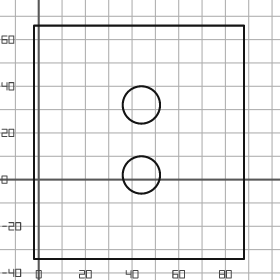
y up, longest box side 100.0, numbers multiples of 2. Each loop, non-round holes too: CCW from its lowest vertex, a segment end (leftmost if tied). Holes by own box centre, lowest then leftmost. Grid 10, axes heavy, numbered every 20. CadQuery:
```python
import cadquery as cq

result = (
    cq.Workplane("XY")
    .moveTo(-2.0, -34.0)
    .lineTo(88.0, -34.0)
    .lineTo(88.0, 66.0)
    .lineTo(-2.0, 66.0)
    .close()
    .moveTo(44.0, 2.0)
    .circle(8.0)
    .moveTo(44.0, 32.0)
    .circle(8.0)
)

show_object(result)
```